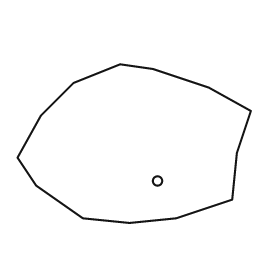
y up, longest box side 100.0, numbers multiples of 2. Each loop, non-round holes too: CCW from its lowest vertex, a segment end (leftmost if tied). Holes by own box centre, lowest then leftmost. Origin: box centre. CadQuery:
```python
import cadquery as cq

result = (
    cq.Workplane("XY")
    .moveTo(-2.0, -34.0)
    .lineTo(18.0, -32.0)
    .lineTo(42.0, -24.0)
    .lineTo(44.0, -4.0)
    .lineTo(50.0, 14.0)
    .lineTo(32.0, 24.0)
    .lineTo(8.0, 32.0)
    .lineTo(-6.0, 34.0)
    .lineTo(-26.0, 26.0)
    .lineTo(-40.0, 12.0)
    .lineTo(-50.0, -6.0)
    .lineTo(-42.0, -18.0)
    .lineTo(-22.0, -32.0)
    .close()
    .moveTo(10.0, -16.0)
    .circle(2.0)
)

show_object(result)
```